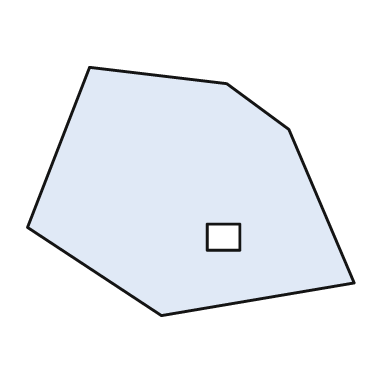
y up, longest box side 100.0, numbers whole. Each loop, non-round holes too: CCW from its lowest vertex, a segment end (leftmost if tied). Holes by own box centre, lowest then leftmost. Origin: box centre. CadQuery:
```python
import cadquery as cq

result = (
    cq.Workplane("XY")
    .moveTo(-9.0, -38.0)
    .lineTo(50.0, -28.0)
    .lineTo(30.0, 19.0)
    .lineTo(11.0, 33.0)
    .lineTo(-31.0, 38.0)
    .lineTo(-50.0, -11.0)
    .close()
    .moveTo(5.0, -18.0)
    .lineTo(15.0, -18.0)
    .lineTo(15.0, -10.0)
    .lineTo(5.0, -10.0)
    .close()
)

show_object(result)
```